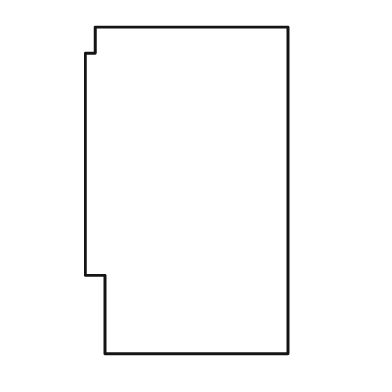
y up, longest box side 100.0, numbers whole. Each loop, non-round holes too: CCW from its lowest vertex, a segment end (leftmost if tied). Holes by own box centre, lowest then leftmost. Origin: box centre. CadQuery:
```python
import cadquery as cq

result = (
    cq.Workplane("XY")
    .moveTo(-25.0, -50.0)
    .lineTo(31.0, -50.0)
    .lineTo(31.0, 50.0)
    .lineTo(-28.0, 50.0)
    .lineTo(-28.0, 42.0)
    .lineTo(-31.0, 42.0)
    .lineTo(-31.0, -26.0)
    .lineTo(-25.0, -26.0)
    .close()
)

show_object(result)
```